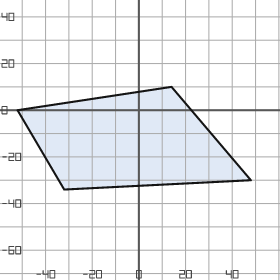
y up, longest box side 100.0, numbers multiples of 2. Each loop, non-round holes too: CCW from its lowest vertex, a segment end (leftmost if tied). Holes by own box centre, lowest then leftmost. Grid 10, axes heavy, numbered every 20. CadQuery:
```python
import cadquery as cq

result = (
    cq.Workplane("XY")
    .moveTo(-32.0, -34.0)
    .lineTo(48.0, -30.0)
    .lineTo(14.0, 10.0)
    .lineTo(-52.0, 0.0)
    .close()
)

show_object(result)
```